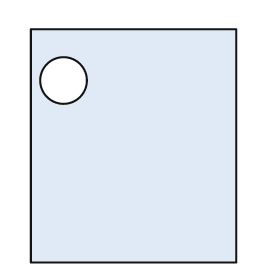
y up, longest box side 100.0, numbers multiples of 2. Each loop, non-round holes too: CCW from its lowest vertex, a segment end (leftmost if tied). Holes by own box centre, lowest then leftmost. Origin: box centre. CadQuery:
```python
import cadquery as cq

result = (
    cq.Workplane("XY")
    .moveTo(-44.0, -50.0)
    .lineTo(44.0, -50.0)
    .lineTo(44.0, 50.0)
    .lineTo(-44.0, 50.0)
    .close()
    .moveTo(-30.0, 28.0)
    .circle(10.0)
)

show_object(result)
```